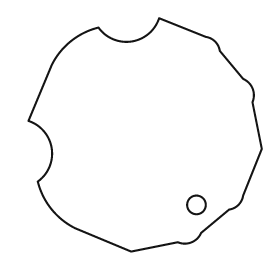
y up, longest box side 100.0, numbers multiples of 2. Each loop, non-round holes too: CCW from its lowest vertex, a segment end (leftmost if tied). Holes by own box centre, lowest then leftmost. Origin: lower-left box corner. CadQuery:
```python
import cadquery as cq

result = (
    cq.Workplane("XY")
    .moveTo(44.0, 0.0)
    .lineTo(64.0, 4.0)
    .threePointArc((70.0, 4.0), (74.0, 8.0))
    .lineTo(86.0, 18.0)
    .threePointArc((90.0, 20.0), (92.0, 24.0))
    .lineTo(100.0, 44.0)
    .lineTo(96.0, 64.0)
    .threePointArc((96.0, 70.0), (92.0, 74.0))
    .lineTo(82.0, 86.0)
    .threePointArc((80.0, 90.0), (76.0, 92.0))
    .lineTo(56.0, 100.0)
    .threePointArc((44.0, 90.0), (30.0, 96.0))
    .threePointArc((18.0, 90.0), (10.0, 80.0))
    .lineTo(0.0, 56.0)
    .threePointArc((10.0, 44.0), (4.0, 30.0))
    .threePointArc((10.0, 18.0), (20.0, 10.0))
    .close()
    .moveTo(72.0, 20.0)
    .circle(4.0)
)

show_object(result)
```